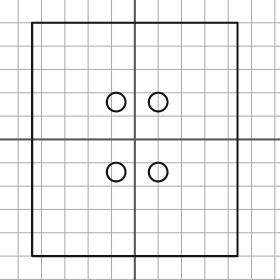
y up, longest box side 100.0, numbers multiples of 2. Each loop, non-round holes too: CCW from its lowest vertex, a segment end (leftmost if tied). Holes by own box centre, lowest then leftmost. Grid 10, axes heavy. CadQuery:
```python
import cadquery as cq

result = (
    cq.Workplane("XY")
    .moveTo(-44.0, -50.0)
    .lineTo(44.0, -50.0)
    .lineTo(44.0, 50.0)
    .lineTo(-44.0, 50.0)
    .close()
    .moveTo(-8.0, -14.0)
    .circle(4.0)
    .moveTo(10.0, -14.0)
    .circle(4.0)
    .moveTo(-8.0, 16.0)
    .circle(4.0)
    .moveTo(10.0, 16.0)
    .circle(4.0)
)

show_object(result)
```